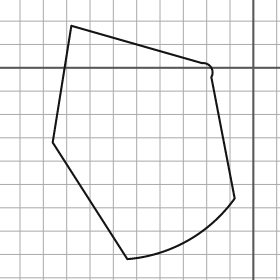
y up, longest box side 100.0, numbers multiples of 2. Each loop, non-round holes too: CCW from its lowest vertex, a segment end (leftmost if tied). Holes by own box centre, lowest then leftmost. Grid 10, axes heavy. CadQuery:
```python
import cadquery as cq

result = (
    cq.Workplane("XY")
    .moveTo(-54.0, -82.0)
    .threePointArc((-28.0, -74.0), (-8.0, -56.0))
    .lineTo(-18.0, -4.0)
    .threePointArc((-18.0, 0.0), (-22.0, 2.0))
    .lineTo(-78.0, 18.0)
    .lineTo(-86.0, -32.0)
    .close()
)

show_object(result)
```